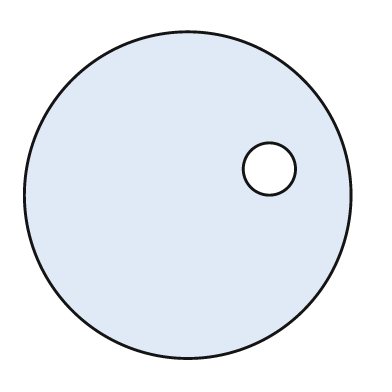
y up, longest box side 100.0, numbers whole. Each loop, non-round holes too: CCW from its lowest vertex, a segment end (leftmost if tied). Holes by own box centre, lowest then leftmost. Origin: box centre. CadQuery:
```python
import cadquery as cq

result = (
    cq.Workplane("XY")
    .moveTo(0.0, 0.0)
    .circle(50.0)
    .moveTo(25.0, 8.0)
    .circle(8.0)
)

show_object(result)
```